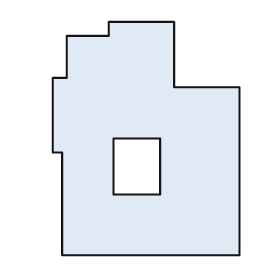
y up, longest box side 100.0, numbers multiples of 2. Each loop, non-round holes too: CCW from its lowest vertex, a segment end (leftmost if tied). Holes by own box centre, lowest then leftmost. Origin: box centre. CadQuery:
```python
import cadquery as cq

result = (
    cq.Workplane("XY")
    .moveTo(-36.0, -50.0)
    .lineTo(40.0, -50.0)
    .lineTo(40.0, 22.0)
    .lineTo(12.0, 22.0)
    .lineTo(12.0, 50.0)
    .lineTo(-16.0, 50.0)
    .lineTo(-16.0, 44.0)
    .lineTo(-34.0, 44.0)
    .lineTo(-34.0, 26.0)
    .lineTo(-40.0, 26.0)
    .lineTo(-40.0, -6.0)
    .lineTo(-36.0, -6.0)
    .close()
    .moveTo(-14.0, -24.0)
    .lineTo(6.0, -24.0)
    .lineTo(6.0, 0.0)
    .lineTo(-14.0, 0.0)
    .close()
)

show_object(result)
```